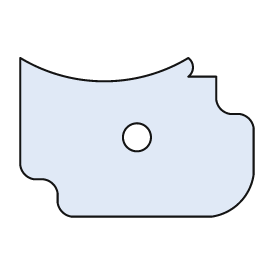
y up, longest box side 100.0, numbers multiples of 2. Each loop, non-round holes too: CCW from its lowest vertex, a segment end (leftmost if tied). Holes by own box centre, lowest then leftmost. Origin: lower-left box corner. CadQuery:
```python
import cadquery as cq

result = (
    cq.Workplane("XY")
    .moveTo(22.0, 0.0)
    .lineTo(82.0, 0.0)
    .threePointArc((94.0, 6.0), (100.0, 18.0))
    .lineTo(100.0, 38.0)
    .threePointArc((98.0, 42.0), (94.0, 44.0))
    .lineTo(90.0, 44.0)
    .threePointArc((86.0, 46.0), (84.0, 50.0))
    .lineTo(84.0, 60.0)
    .lineTo(72.0, 60.0)
    .threePointArc((74.0, 64.0), (72.0, 68.0))
    .threePointArc((36.0, 58.0), (0.0, 68.0))
    .lineTo(0.0, 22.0)
    .threePointArc((2.0, 18.0), (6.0, 16.0))
    .lineTo(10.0, 16.0)
    .threePointArc((14.0, 14.0), (16.0, 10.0))
    .lineTo(16.0, 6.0)
    .threePointArc((18.0, 2.0), (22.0, 0.0))
    .close()
    .moveTo(50.0, 34.0)
    .circle(6.0)
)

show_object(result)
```